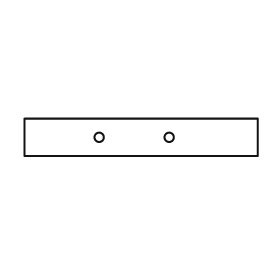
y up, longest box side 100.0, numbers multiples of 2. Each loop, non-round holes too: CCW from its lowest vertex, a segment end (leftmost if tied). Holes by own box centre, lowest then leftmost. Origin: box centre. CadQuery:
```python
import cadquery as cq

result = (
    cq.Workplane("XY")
    .moveTo(-50.0, -8.0)
    .lineTo(50.0, -8.0)
    .lineTo(50.0, 8.0)
    .lineTo(-50.0, 8.0)
    .close()
    .moveTo(-18.0, 0.0)
    .circle(2.0)
    .moveTo(12.0, 0.0)
    .circle(2.0)
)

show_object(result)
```